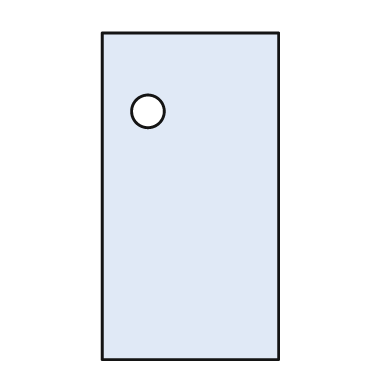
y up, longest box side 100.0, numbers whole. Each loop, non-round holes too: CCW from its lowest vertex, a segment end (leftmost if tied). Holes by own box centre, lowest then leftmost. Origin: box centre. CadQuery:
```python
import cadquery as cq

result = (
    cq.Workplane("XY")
    .moveTo(-27.0, -50.0)
    .lineTo(27.0, -50.0)
    .lineTo(27.0, 50.0)
    .lineTo(-27.0, 50.0)
    .close()
    .moveTo(-13.0, 26.0)
    .circle(5.0)
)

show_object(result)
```